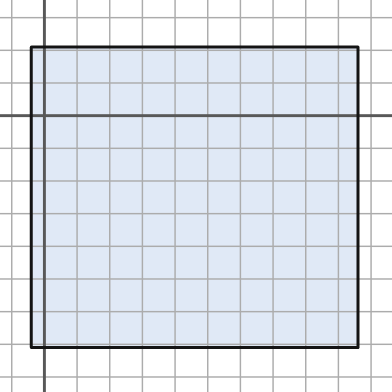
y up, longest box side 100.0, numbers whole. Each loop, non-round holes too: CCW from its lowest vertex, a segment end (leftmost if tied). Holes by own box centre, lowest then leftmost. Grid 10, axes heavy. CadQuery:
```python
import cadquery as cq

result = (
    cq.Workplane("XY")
    .moveTo(-4.0, -71.0)
    .lineTo(96.0, -71.0)
    .lineTo(96.0, 21.0)
    .lineTo(-4.0, 21.0)
    .close()
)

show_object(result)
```